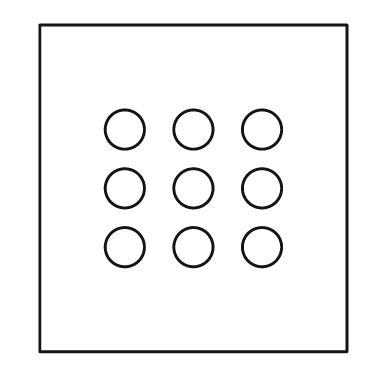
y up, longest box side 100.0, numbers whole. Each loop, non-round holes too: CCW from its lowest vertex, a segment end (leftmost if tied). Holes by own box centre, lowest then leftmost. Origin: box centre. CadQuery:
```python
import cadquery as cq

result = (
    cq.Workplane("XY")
    .moveTo(-47.0, -50.0)
    .lineTo(47.0, -50.0)
    .lineTo(47.0, 50.0)
    .lineTo(-47.0, 50.0)
    .close()
    .moveTo(-21.0, -18.0)
    .circle(6.0)
    .moveTo(0.0, -18.0)
    .circle(6.0)
    .moveTo(21.0, -18.0)
    .circle(6.0)
    .moveTo(-21.0, 0.0)
    .circle(6.0)
    .moveTo(0.0, 0.0)
    .circle(6.0)
    .moveTo(21.0, 0.0)
    .circle(6.0)
    .moveTo(-21.0, 18.0)
    .circle(6.0)
    .moveTo(0.0, 18.0)
    .circle(6.0)
    .moveTo(21.0, 18.0)
    .circle(6.0)
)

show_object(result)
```